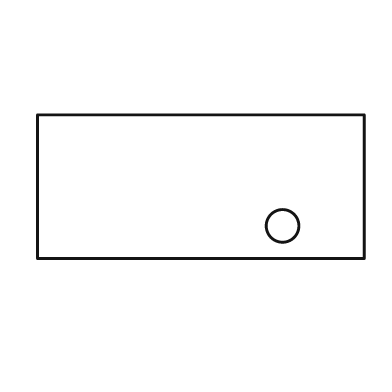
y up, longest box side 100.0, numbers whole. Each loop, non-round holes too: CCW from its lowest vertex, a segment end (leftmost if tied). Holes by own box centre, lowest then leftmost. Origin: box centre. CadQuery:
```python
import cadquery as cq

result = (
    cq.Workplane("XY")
    .moveTo(-50.0, -22.0)
    .lineTo(50.0, -22.0)
    .lineTo(50.0, 22.0)
    .lineTo(-50.0, 22.0)
    .close()
    .moveTo(25.0, -12.0)
    .circle(5.0)
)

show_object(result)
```